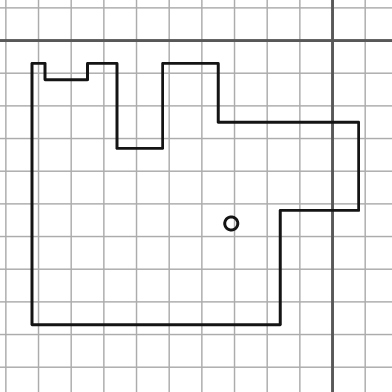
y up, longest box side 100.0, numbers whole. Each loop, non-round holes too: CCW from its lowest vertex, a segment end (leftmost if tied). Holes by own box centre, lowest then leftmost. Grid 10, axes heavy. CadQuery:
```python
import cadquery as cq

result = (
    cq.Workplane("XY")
    .moveTo(-92.0, -87.0)
    .lineTo(-16.0, -87.0)
    .lineTo(-16.0, -52.0)
    .lineTo(8.0, -52.0)
    .lineTo(8.0, -25.0)
    .lineTo(-35.0, -25.0)
    .lineTo(-35.0, -7.0)
    .lineTo(-52.0, -7.0)
    .lineTo(-52.0, -33.0)
    .lineTo(-66.0, -33.0)
    .lineTo(-66.0, -7.0)
    .lineTo(-75.0, -7.0)
    .lineTo(-75.0, -12.0)
    .lineTo(-88.0, -12.0)
    .lineTo(-88.0, -7.0)
    .lineTo(-92.0, -7.0)
    .close()
    .moveTo(-31.0, -56.0)
    .circle(2.0)
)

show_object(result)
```